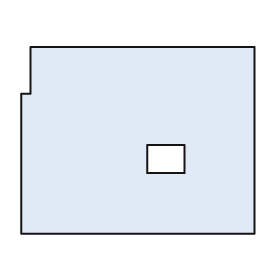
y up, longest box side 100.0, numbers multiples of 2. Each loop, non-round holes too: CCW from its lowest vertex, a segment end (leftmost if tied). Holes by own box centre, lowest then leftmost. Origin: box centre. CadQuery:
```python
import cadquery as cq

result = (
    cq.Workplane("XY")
    .moveTo(-50.0, -40.0)
    .lineTo(50.0, -40.0)
    .lineTo(50.0, 40.0)
    .lineTo(-46.0, 40.0)
    .lineTo(-46.0, 20.0)
    .lineTo(-50.0, 20.0)
    .close()
    .moveTo(4.0, -14.0)
    .lineTo(20.0, -14.0)
    .lineTo(20.0, -2.0)
    .lineTo(4.0, -2.0)
    .close()
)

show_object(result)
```